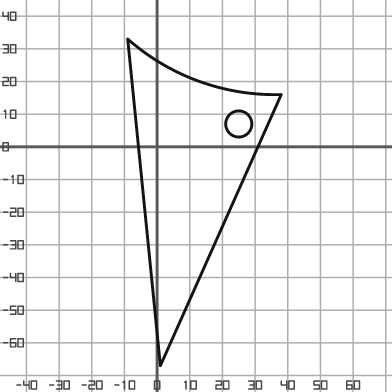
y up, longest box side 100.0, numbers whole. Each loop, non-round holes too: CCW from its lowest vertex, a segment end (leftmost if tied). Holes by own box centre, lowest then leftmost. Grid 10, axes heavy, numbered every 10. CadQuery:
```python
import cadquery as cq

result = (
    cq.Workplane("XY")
    .moveTo(1.0, -67.0)
    .lineTo(38.0, 16.0)
    .threePointArc((13.0, 20.0), (-9.0, 33.0))
    .close()
    .moveTo(25.0, 7.0)
    .circle(4.0)
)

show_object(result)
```